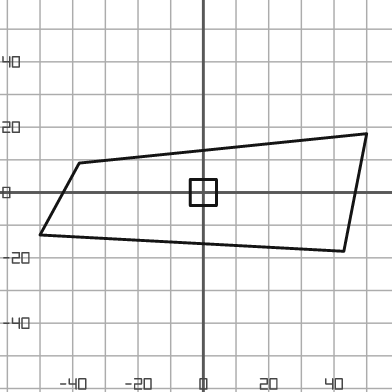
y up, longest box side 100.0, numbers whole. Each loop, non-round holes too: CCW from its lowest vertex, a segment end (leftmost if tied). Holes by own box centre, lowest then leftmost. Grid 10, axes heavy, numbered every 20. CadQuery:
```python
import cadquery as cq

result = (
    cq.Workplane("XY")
    .moveTo(43.0, -18.0)
    .lineTo(50.0, 18.0)
    .lineTo(-38.0, 9.0)
    .lineTo(-50.0, -13.0)
    .close()
    .moveTo(-4.0, -4.0)
    .lineTo(4.0, -4.0)
    .lineTo(4.0, 4.0)
    .lineTo(-4.0, 4.0)
    .close()
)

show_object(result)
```